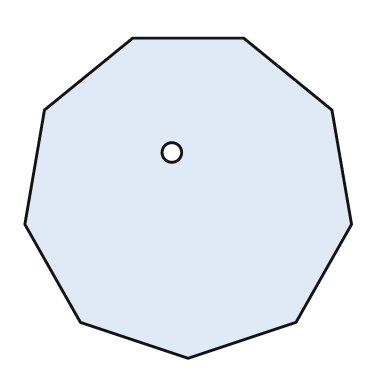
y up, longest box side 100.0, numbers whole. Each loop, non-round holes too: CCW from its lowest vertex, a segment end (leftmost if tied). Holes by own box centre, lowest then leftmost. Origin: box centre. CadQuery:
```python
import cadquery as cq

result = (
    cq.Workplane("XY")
    .moveTo(0.0, -49.0)
    .lineTo(33.0, -38.0)
    .lineTo(50.0, -8.0)
    .lineTo(44.0, 27.0)
    .lineTo(17.0, 49.0)
    .lineTo(-17.0, 49.0)
    .lineTo(-44.0, 27.0)
    .lineTo(-50.0, -8.0)
    .lineTo(-33.0, -38.0)
    .close()
    .moveTo(-5.0, 14.0)
    .circle(3.0)
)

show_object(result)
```